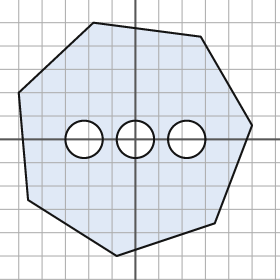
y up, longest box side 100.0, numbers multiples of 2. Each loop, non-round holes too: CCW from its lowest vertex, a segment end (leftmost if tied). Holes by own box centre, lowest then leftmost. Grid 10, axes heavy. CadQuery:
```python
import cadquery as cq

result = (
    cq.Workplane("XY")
    .moveTo(-8.0, -50.0)
    .lineTo(34.0, -36.0)
    .lineTo(50.0, 6.0)
    .lineTo(28.0, 44.0)
    .lineTo(-18.0, 50.0)
    .lineTo(-50.0, 20.0)
    .lineTo(-46.0, -26.0)
    .close()
    .moveTo(-22.0, 0.0)
    .circle(8.0)
    .moveTo(0.0, 0.0)
    .circle(8.0)
    .moveTo(22.0, 0.0)
    .circle(8.0)
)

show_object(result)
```